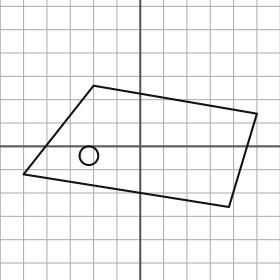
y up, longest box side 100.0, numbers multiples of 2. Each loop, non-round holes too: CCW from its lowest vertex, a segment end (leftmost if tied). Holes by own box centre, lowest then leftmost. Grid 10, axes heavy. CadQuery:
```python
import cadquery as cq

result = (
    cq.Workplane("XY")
    .moveTo(38.0, -26.0)
    .lineTo(50.0, 14.0)
    .lineTo(-20.0, 26.0)
    .lineTo(-50.0, -12.0)
    .close()
    .moveTo(-22.0, -4.0)
    .circle(4.0)
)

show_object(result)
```